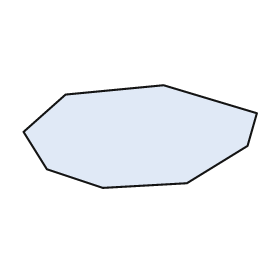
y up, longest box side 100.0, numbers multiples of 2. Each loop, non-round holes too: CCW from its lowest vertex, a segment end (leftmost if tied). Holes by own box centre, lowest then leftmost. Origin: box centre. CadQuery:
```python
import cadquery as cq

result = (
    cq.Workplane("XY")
    .moveTo(-16.0, -22.0)
    .lineTo(20.0, -20.0)
    .lineTo(46.0, -4.0)
    .lineTo(50.0, 10.0)
    .lineTo(10.0, 22.0)
    .lineTo(-32.0, 18.0)
    .lineTo(-50.0, 2.0)
    .lineTo(-40.0, -14.0)
    .close()
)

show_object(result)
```